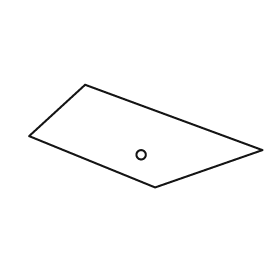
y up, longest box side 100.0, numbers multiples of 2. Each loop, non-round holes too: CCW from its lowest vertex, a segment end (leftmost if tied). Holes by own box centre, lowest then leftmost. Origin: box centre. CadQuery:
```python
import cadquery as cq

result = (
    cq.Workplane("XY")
    .moveTo(4.0, -22.0)
    .lineTo(50.0, -6.0)
    .lineTo(-26.0, 22.0)
    .lineTo(-50.0, 0.0)
    .close()
    .moveTo(-2.0, -8.0)
    .circle(2.0)
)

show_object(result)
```